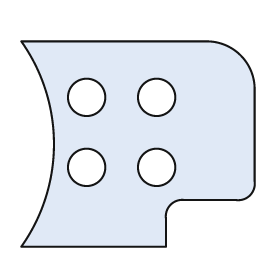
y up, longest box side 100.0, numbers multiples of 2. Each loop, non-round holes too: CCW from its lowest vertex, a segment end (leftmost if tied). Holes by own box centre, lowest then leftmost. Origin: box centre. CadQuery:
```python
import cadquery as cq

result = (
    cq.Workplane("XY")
    .moveTo(-50.0, -44.0)
    .lineTo(12.0, -44.0)
    .lineTo(12.0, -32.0)
    .threePointArc((14.0, -26.0), (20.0, -24.0))
    .lineTo(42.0, -24.0)
    .threePointArc((48.0, -22.0), (50.0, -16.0))
    .lineTo(50.0, 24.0)
    .threePointArc((44.0, 38.0), (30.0, 44.0))
    .lineTo(-50.0, 44.0)
    .threePointArc((-36.0, 0.0), (-50.0, -44.0))
    .close()
    .moveTo(-22.0, -10.0)
    .circle(8.0)
    .moveTo(8.0, -10.0)
    .circle(8.0)
    .moveTo(-22.0, 20.0)
    .circle(8.0)
    .moveTo(8.0, 20.0)
    .circle(8.0)
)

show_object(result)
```